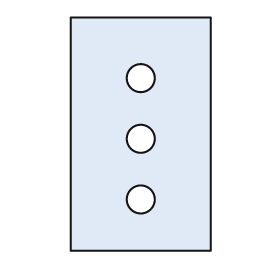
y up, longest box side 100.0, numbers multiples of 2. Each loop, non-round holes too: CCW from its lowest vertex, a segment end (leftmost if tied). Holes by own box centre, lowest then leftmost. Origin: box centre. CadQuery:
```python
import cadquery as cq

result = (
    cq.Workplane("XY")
    .moveTo(-30.0, -50.0)
    .lineTo(30.0, -50.0)
    .lineTo(30.0, 50.0)
    .lineTo(-30.0, 50.0)
    .close()
    .moveTo(0.0, -28.0)
    .circle(6.0)
    .moveTo(0.0, -2.0)
    .circle(6.0)
    .moveTo(0.0, 24.0)
    .circle(6.0)
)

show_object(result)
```